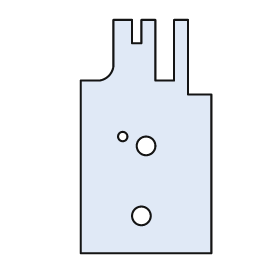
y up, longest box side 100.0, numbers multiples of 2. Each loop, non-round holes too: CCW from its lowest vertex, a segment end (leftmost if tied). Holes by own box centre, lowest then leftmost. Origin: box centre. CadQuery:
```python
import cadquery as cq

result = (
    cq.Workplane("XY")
    .moveTo(-28.0, -50.0)
    .lineTo(28.0, -50.0)
    .lineTo(28.0, 18.0)
    .lineTo(18.0, 18.0)
    .lineTo(18.0, 50.0)
    .lineTo(12.0, 50.0)
    .lineTo(12.0, 24.0)
    .lineTo(4.0, 24.0)
    .lineTo(4.0, 50.0)
    .lineTo(-2.0, 50.0)
    .lineTo(-2.0, 40.0)
    .lineTo(-6.0, 40.0)
    .lineTo(-6.0, 50.0)
    .lineTo(-14.0, 50.0)
    .lineTo(-14.0, 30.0)
    .threePointArc((-16.0, 26.0), (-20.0, 24.0))
    .lineTo(-28.0, 24.0)
    .close()
    .moveTo(-2.0, -34.0)
    .circle(4.0)
    .moveTo(0.0, -4.0)
    .circle(4.0)
    .moveTo(-10.0, 0.0)
    .circle(2.0)
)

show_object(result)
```